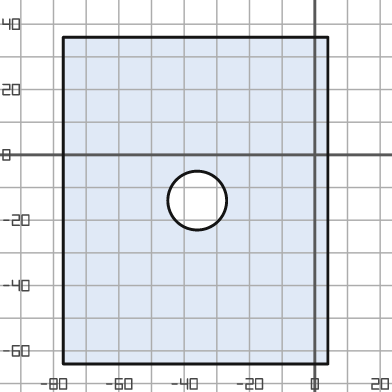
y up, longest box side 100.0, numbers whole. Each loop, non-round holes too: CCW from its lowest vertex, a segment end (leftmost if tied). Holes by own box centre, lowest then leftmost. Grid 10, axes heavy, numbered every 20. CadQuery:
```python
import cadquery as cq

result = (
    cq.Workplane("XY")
    .moveTo(-77.0, -64.0)
    .lineTo(4.0, -64.0)
    .lineTo(4.0, 36.0)
    .lineTo(-77.0, 36.0)
    .close()
    .moveTo(-36.0, -14.0)
    .circle(9.0)
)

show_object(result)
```